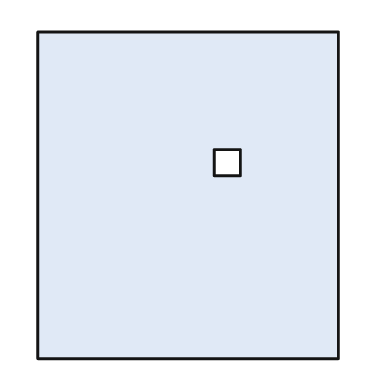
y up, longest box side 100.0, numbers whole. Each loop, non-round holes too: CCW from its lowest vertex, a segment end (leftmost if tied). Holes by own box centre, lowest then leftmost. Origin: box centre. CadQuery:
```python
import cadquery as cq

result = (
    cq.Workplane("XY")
    .moveTo(-46.0, -50.0)
    .lineTo(46.0, -50.0)
    .lineTo(46.0, 50.0)
    .lineTo(-46.0, 50.0)
    .close()
    .moveTo(8.0, 6.0)
    .lineTo(16.0, 6.0)
    .lineTo(16.0, 14.0)
    .lineTo(8.0, 14.0)
    .close()
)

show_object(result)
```